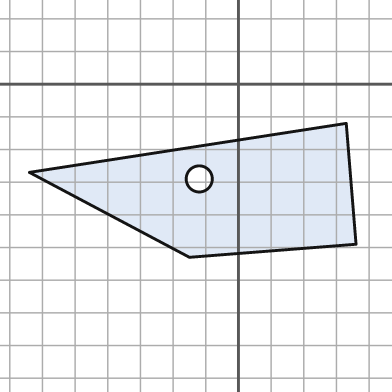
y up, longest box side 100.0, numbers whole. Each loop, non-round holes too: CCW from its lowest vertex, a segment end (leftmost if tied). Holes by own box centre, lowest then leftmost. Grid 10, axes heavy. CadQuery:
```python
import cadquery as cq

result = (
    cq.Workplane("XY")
    .moveTo(-15.0, -53.0)
    .lineTo(36.0, -49.0)
    .lineTo(33.0, -12.0)
    .lineTo(-64.0, -27.0)
    .close()
    .moveTo(-12.0, -29.0)
    .circle(4.0)
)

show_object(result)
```